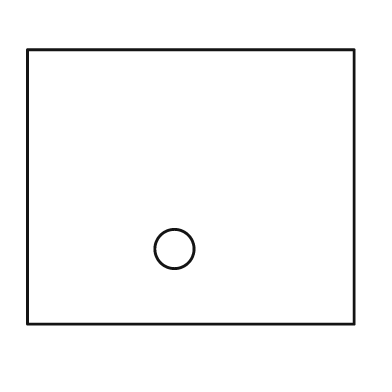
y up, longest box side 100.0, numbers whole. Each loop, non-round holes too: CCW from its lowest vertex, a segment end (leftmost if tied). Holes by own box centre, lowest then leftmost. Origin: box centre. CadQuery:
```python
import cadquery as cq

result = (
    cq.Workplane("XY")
    .moveTo(-50.0, -42.0)
    .lineTo(50.0, -42.0)
    .lineTo(50.0, 42.0)
    .lineTo(-50.0, 42.0)
    .close()
    .moveTo(-5.0, -19.0)
    .circle(6.0)
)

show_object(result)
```